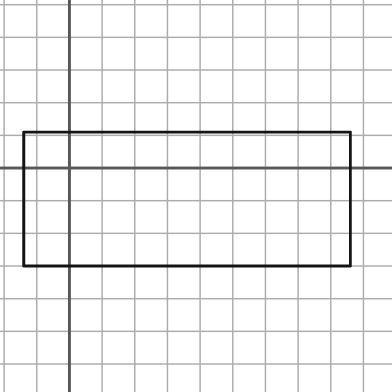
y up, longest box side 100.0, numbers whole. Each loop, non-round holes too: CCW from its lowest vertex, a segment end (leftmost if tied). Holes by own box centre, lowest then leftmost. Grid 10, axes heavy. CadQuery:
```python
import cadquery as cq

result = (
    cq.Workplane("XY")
    .moveTo(-14.0, -30.0)
    .lineTo(86.0, -30.0)
    .lineTo(86.0, 11.0)
    .lineTo(-14.0, 11.0)
    .close()
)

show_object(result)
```